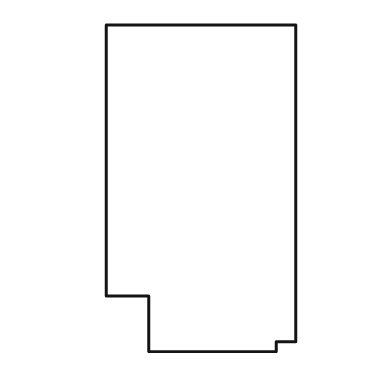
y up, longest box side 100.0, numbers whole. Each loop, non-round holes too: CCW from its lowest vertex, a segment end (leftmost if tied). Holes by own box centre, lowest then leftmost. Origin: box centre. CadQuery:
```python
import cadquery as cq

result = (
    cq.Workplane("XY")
    .moveTo(-16.0, -50.0)
    .lineTo(23.0, -50.0)
    .lineTo(23.0, -47.0)
    .lineTo(29.0, -47.0)
    .lineTo(29.0, 50.0)
    .lineTo(-29.0, 50.0)
    .lineTo(-29.0, -33.0)
    .lineTo(-16.0, -33.0)
    .close()
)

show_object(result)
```